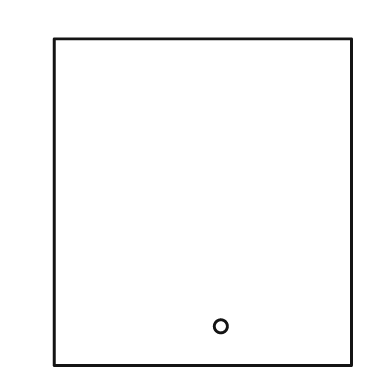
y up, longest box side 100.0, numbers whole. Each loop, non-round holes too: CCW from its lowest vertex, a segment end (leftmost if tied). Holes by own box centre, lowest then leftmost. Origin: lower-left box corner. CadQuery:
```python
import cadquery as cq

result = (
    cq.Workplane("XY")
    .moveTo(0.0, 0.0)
    .lineTo(91.0, 0.0)
    .lineTo(91.0, 100.0)
    .lineTo(0.0, 100.0)
    .close()
    .moveTo(51.0, 12.0)
    .circle(2.0)
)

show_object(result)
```